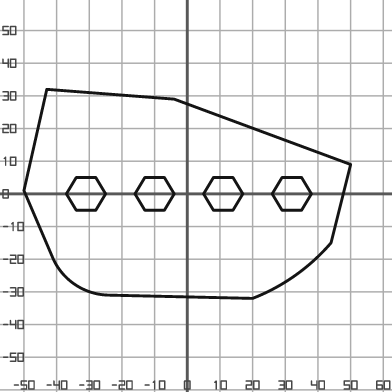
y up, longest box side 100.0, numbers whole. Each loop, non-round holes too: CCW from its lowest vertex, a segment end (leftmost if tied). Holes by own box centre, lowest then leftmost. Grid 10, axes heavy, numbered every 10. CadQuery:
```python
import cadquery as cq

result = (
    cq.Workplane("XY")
    .moveTo(20.0, -32.0)
    .threePointArc((33.0, -25.0), (44.0, -15.0))
    .lineTo(50.0, 9.0)
    .lineTo(-4.0, 29.0)
    .lineTo(-43.0, 32.0)
    .lineTo(-50.0, 1.0)
    .lineTo(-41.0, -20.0)
    .threePointArc((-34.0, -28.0), (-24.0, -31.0))
    .close()
    .moveTo(-34.0, -5.0)
    .lineTo(-28.0, -5.0)
    .lineTo(-25.0, 0.0)
    .lineTo(-28.0, 5.0)
    .lineTo(-34.0, 5.0)
    .lineTo(-37.0, 0.0)
    .close()
    .moveTo(-13.0, -5.0)
    .lineTo(-7.0, -5.0)
    .lineTo(-4.0, 0.0)
    .lineTo(-7.0, 5.0)
    .lineTo(-13.0, 5.0)
    .lineTo(-16.0, 0.0)
    .close()
    .moveTo(8.0, -5.0)
    .lineTo(14.0, -5.0)
    .lineTo(17.0, 0.0)
    .lineTo(14.0, 5.0)
    .lineTo(8.0, 5.0)
    .lineTo(5.0, 0.0)
    .close()
    .moveTo(29.0, -5.0)
    .lineTo(35.0, -5.0)
    .lineTo(38.0, 0.0)
    .lineTo(35.0, 5.0)
    .lineTo(29.0, 5.0)
    .lineTo(26.0, 0.0)
    .close()
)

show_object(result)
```